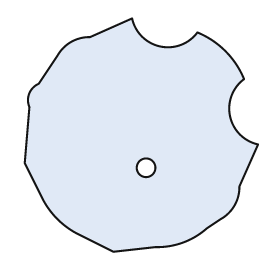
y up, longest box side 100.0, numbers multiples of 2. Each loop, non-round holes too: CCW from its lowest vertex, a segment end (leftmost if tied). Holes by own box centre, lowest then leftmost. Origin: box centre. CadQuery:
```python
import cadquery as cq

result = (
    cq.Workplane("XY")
    .moveTo(-12.0, -50.0)
    .lineTo(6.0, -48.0)
    .threePointArc((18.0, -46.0), (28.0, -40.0))
    .lineTo(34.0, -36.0)
    .threePointArc((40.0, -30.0), (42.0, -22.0))
    .lineTo(50.0, -4.0)
    .threePointArc((38.0, 8.0), (44.0, 24.0))
    .threePointArc((36.0, 36.0), (24.0, 44.0))
    .threePointArc((8.0, 38.0), (-4.0, 50.0))
    .lineTo(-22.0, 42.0)
    .threePointArc((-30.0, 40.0), (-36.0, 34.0))
    .lineTo(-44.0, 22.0)
    .threePointArc((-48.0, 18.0), (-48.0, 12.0))
    .lineTo(-50.0, -12.0)
    .lineTo(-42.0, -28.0)
    .threePointArc((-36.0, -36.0), (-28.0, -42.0))
    .close()
    .moveTo(2.0, -14.0)
    .circle(4.0)
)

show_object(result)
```